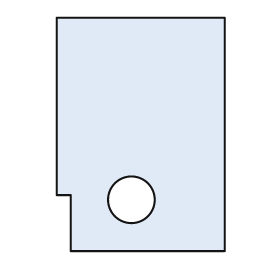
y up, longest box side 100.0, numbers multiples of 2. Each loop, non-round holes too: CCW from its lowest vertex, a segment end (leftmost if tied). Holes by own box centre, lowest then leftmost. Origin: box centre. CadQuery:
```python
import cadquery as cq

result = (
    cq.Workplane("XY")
    .moveTo(-30.0, -50.0)
    .lineTo(36.0, -50.0)
    .lineTo(36.0, 50.0)
    .lineTo(-36.0, 50.0)
    .lineTo(-36.0, -26.0)
    .lineTo(-30.0, -26.0)
    .close()
    .moveTo(-4.0, -28.0)
    .circle(10.0)
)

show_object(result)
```